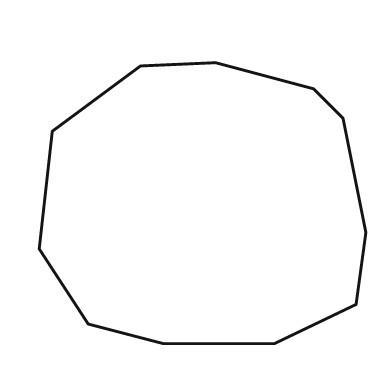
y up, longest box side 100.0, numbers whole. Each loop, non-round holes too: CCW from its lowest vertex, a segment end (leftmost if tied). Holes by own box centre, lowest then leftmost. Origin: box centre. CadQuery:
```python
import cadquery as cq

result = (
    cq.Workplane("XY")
    .moveTo(-12.0, -43.0)
    .lineTo(22.0, -43.0)
    .lineTo(47.0, -31.0)
    .lineTo(50.0, -9.0)
    .lineTo(43.0, 26.0)
    .lineTo(34.0, 35.0)
    .lineTo(4.0, 43.0)
    .lineTo(-19.0, 42.0)
    .lineTo(-46.0, 22.0)
    .lineTo(-50.0, -14.0)
    .lineTo(-35.0, -37.0)
    .close()
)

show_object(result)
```